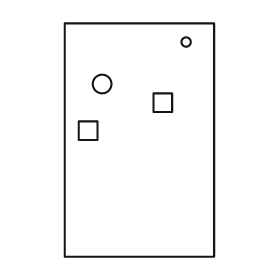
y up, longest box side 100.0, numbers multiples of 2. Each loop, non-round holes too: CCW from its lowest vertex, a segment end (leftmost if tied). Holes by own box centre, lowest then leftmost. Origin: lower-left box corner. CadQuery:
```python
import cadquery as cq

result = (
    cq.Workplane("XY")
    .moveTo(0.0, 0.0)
    .lineTo(64.0, 0.0)
    .lineTo(64.0, 100.0)
    .lineTo(0.0, 100.0)
    .close()
    .moveTo(6.0, 50.0)
    .lineTo(14.0, 50.0)
    .lineTo(14.0, 58.0)
    .lineTo(6.0, 58.0)
    .close()
    .moveTo(38.0, 62.0)
    .lineTo(46.0, 62.0)
    .lineTo(46.0, 70.0)
    .lineTo(38.0, 70.0)
    .close()
    .moveTo(16.0, 74.0)
    .circle(4.0)
    .moveTo(52.0, 92.0)
    .circle(2.0)
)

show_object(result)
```